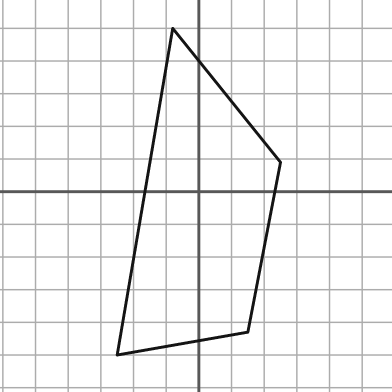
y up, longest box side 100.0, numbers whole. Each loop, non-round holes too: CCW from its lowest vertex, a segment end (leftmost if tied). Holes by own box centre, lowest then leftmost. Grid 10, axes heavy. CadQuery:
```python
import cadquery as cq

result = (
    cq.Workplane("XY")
    .moveTo(-25.0, -50.0)
    .lineTo(15.0, -43.0)
    .lineTo(25.0, 9.0)
    .lineTo(-8.0, 50.0)
    .close()
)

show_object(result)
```